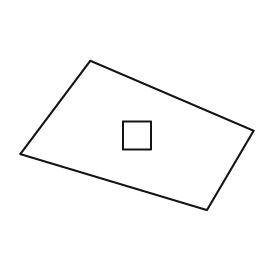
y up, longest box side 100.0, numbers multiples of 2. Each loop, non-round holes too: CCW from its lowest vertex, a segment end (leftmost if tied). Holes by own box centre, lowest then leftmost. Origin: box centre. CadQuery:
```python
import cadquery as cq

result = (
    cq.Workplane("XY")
    .moveTo(30.0, -32.0)
    .lineTo(50.0, 2.0)
    .lineTo(-20.0, 32.0)
    .lineTo(-50.0, -8.0)
    .close()
    .moveTo(-6.0, -6.0)
    .lineTo(6.0, -6.0)
    .lineTo(6.0, 6.0)
    .lineTo(-6.0, 6.0)
    .close()
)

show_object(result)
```